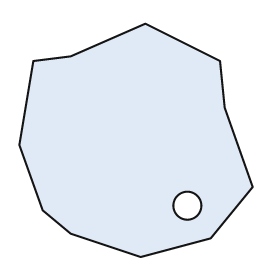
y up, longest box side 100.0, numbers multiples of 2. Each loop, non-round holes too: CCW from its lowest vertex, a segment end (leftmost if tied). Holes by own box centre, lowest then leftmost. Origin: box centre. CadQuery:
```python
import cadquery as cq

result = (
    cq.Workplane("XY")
    .moveTo(2.0, -50.0)
    .lineTo(32.0, -42.0)
    .lineTo(50.0, -20.0)
    .lineTo(38.0, 14.0)
    .lineTo(36.0, 34.0)
    .lineTo(4.0, 50.0)
    .lineTo(-28.0, 36.0)
    .lineTo(-44.0, 34.0)
    .lineTo(-50.0, -2.0)
    .lineTo(-40.0, -30.0)
    .lineTo(-28.0, -40.0)
    .close()
    .moveTo(22.0, -28.0)
    .circle(6.0)
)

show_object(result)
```